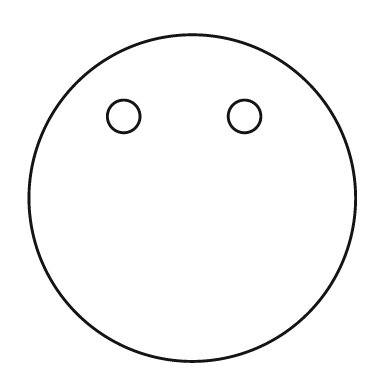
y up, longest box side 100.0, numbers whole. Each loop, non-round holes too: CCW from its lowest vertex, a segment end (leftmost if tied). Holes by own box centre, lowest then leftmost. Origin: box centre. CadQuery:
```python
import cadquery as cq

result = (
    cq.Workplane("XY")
    .moveTo(0.0, 0.0)
    .circle(50.0)
    .moveTo(-21.0, 25.0)
    .circle(5.0)
    .moveTo(16.0, 25.0)
    .circle(5.0)
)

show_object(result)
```